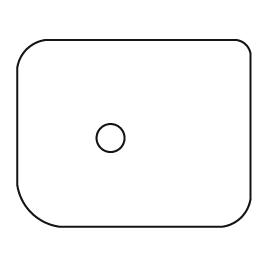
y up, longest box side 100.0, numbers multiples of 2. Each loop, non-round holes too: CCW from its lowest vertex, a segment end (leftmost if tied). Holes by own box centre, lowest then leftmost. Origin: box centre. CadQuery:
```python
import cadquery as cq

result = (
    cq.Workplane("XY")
    .moveTo(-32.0, -40.0)
    .lineTo(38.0, -40.0)
    .threePointArc((46.0, -36.0), (50.0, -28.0))
    .lineTo(50.0, 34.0)
    .threePointArc((48.0, 38.0), (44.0, 40.0))
    .lineTo(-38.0, 40.0)
    .threePointArc((-46.0, 36.0), (-50.0, 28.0))
    .lineTo(-50.0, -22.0)
    .threePointArc((-44.0, -34.0), (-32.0, -40.0))
    .close()
    .moveTo(-10.0, -2.0)
    .circle(6.0)
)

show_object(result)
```